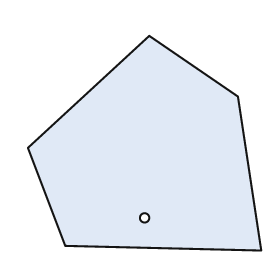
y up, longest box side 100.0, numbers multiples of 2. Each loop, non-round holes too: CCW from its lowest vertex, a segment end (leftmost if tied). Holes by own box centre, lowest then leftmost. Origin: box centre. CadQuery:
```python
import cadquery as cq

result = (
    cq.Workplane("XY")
    .moveTo(50.0, -46.0)
    .lineTo(40.0, 20.0)
    .lineTo(2.0, 46.0)
    .lineTo(-50.0, -2.0)
    .lineTo(-34.0, -44.0)
    .close()
    .moveTo(0.0, -32.0)
    .circle(2.0)
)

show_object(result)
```